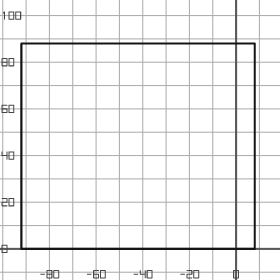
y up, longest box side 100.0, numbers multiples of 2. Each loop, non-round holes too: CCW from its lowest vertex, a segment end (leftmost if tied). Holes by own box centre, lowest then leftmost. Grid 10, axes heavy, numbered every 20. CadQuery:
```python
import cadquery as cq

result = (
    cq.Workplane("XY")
    .moveTo(-92.0, 0.0)
    .lineTo(8.0, 0.0)
    .lineTo(8.0, 88.0)
    .lineTo(-92.0, 88.0)
    .close()
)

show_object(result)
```